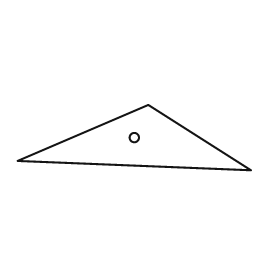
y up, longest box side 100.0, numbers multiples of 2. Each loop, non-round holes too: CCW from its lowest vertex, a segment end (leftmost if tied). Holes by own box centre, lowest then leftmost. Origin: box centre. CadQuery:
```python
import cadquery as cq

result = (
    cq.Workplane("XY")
    .moveTo(50.0, -14.0)
    .lineTo(6.0, 14.0)
    .lineTo(-50.0, -10.0)
    .close()
    .moveTo(0.0, 0.0)
    .circle(2.0)
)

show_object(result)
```